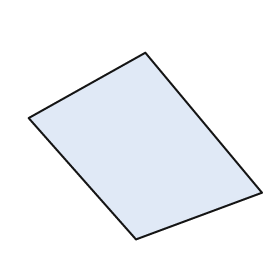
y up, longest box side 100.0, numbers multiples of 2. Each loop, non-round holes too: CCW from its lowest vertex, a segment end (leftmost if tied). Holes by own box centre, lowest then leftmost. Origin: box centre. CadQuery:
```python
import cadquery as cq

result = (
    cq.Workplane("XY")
    .moveTo(-4.0, -40.0)
    .lineTo(50.0, -20.0)
    .lineTo(0.0, 40.0)
    .lineTo(-50.0, 12.0)
    .close()
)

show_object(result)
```